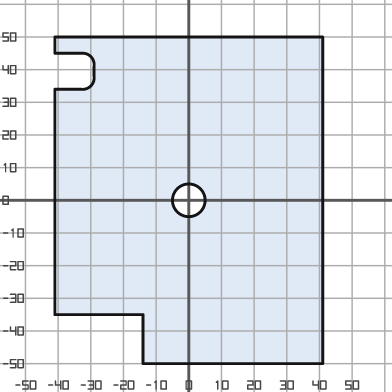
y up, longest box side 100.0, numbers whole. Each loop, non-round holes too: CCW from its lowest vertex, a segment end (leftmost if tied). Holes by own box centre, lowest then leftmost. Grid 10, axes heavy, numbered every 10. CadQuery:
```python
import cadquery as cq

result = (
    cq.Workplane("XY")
    .moveTo(-14.0, -50.0)
    .lineTo(41.0, -50.0)
    .lineTo(41.0, 50.0)
    .lineTo(-41.0, 50.0)
    .lineTo(-41.0, 45.0)
    .lineTo(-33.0, 45.0)
    .threePointArc((-30.0, 44.0), (-29.0, 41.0))
    .lineTo(-29.0, 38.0)
    .threePointArc((-30.0, 35.0), (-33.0, 34.0))
    .lineTo(-41.0, 34.0)
    .lineTo(-41.0, -35.0)
    .lineTo(-14.0, -35.0)
    .close()
    .moveTo(0.0, 0.0)
    .circle(5.0)
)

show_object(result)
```